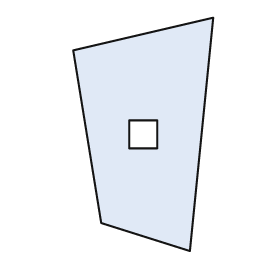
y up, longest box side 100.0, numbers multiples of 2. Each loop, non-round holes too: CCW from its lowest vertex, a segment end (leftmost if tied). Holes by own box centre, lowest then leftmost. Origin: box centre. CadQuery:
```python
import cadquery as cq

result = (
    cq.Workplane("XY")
    .moveTo(20.0, -50.0)
    .lineTo(30.0, 50.0)
    .lineTo(-30.0, 36.0)
    .lineTo(-18.0, -38.0)
    .close()
    .moveTo(-6.0, -6.0)
    .lineTo(6.0, -6.0)
    .lineTo(6.0, 6.0)
    .lineTo(-6.0, 6.0)
    .close()
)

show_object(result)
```